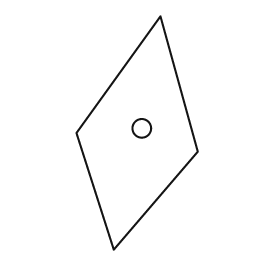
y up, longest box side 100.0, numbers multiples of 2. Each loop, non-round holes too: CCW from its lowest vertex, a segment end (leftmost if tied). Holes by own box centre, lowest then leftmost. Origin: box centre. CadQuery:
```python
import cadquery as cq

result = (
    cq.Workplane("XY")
    .moveTo(-10.0, -50.0)
    .lineTo(26.0, -8.0)
    .lineTo(10.0, 50.0)
    .lineTo(-26.0, 0.0)
    .close()
    .moveTo(2.0, 2.0)
    .circle(4.0)
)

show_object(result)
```